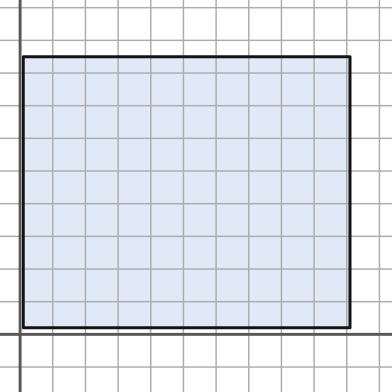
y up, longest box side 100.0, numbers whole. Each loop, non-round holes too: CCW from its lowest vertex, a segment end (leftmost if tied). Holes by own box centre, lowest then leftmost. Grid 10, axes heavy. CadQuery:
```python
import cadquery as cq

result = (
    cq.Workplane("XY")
    .moveTo(1.0, 2.0)
    .lineTo(101.0, 2.0)
    .lineTo(101.0, 85.0)
    .lineTo(1.0, 85.0)
    .close()
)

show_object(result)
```